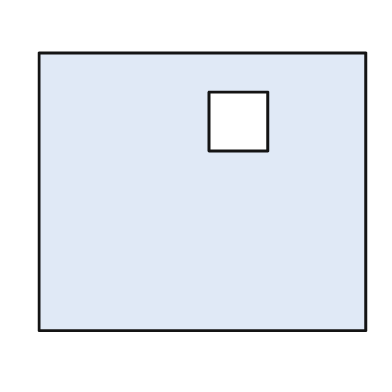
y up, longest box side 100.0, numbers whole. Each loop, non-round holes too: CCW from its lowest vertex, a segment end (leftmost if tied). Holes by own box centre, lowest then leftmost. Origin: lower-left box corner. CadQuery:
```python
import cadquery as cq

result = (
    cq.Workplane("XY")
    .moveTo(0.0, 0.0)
    .lineTo(100.0, 0.0)
    .lineTo(100.0, 85.0)
    .lineTo(0.0, 85.0)
    .close()
    .moveTo(52.0, 55.0)
    .lineTo(70.0, 55.0)
    .lineTo(70.0, 73.0)
    .lineTo(52.0, 73.0)
    .close()
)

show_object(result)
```